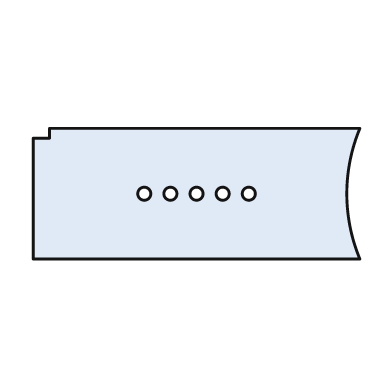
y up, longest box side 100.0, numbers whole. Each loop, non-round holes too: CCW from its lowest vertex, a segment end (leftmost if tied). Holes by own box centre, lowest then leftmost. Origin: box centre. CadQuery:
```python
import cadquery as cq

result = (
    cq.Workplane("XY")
    .moveTo(-50.0, -20.0)
    .lineTo(50.0, -20.0)
    .threePointArc((46.0, 0.0), (50.0, 20.0))
    .lineTo(-45.0, 20.0)
    .lineTo(-45.0, 17.0)
    .lineTo(-50.0, 17.0)
    .close()
    .moveTo(-16.0, 0.0)
    .circle(2.0)
    .moveTo(-8.0, 0.0)
    .circle(2.0)
    .moveTo(0.0, 0.0)
    .circle(2.0)
    .moveTo(8.0, 0.0)
    .circle(2.0)
    .moveTo(16.0, 0.0)
    .circle(2.0)
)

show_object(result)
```